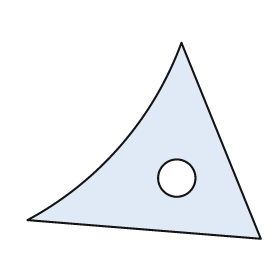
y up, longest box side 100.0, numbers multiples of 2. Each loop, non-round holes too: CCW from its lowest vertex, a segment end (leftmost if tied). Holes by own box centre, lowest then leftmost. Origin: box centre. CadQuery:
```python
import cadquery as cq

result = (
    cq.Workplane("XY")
    .moveTo(50.0, -42.0)
    .lineTo(16.0, 42.0)
    .threePointArc((-10.0, -2.0), (-50.0, -34.0))
    .close()
    .moveTo(14.0, -16.0)
    .circle(8.0)
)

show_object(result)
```